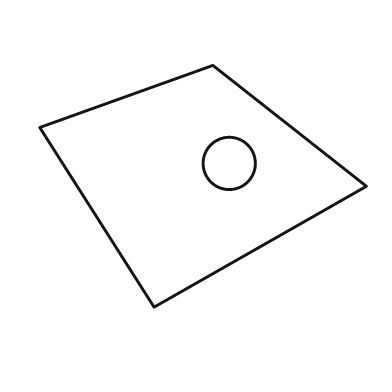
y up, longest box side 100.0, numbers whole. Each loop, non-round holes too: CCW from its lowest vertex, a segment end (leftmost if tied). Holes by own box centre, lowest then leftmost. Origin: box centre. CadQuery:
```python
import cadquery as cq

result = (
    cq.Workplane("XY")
    .moveTo(-15.0, -37.0)
    .lineTo(50.0, 0.0)
    .lineTo(3.0, 37.0)
    .lineTo(-50.0, 18.0)
    .close()
    .moveTo(8.0, 7.0)
    .circle(8.0)
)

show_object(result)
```